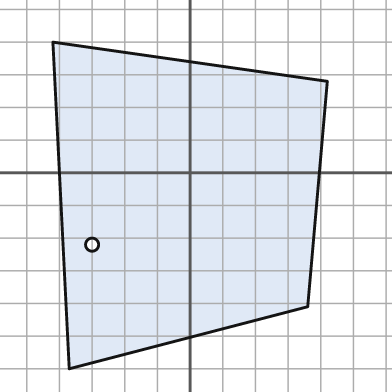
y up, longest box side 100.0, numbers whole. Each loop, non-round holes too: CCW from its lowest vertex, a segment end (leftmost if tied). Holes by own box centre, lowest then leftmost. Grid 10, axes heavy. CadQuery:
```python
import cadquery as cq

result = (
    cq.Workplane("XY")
    .moveTo(-37.0, -60.0)
    .lineTo(36.0, -41.0)
    .lineTo(42.0, 28.0)
    .lineTo(-42.0, 40.0)
    .close()
    .moveTo(-30.0, -22.0)
    .circle(2.0)
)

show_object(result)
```